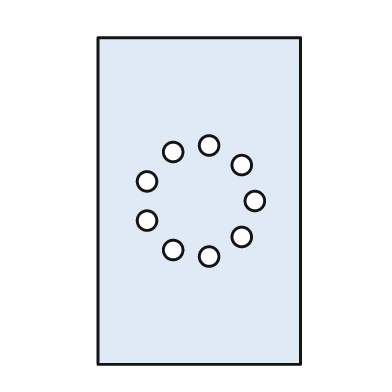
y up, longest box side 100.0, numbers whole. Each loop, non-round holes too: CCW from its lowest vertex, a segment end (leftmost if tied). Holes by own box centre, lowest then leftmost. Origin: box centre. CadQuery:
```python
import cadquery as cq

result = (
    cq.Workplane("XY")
    .moveTo(-31.0, -50.0)
    .lineTo(31.0, -50.0)
    .lineTo(31.0, 50.0)
    .lineTo(-31.0, 50.0)
    .close()
    .moveTo(3.0, -17.0)
    .circle(3.0)
    .moveTo(-8.0, -15.0)
    .circle(3.0)
    .moveTo(13.0, -11.0)
    .circle(3.0)
    .moveTo(-16.0, -6.0)
    .circle(3.0)
    .moveTo(17.0, 0.0)
    .circle(3.0)
    .moveTo(-16.0, 6.0)
    .circle(3.0)
    .moveTo(13.0, 11.0)
    .circle(3.0)
    .moveTo(-8.0, 15.0)
    .circle(3.0)
    .moveTo(3.0, 17.0)
    .circle(3.0)
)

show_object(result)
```